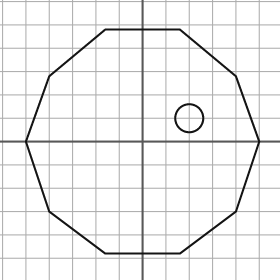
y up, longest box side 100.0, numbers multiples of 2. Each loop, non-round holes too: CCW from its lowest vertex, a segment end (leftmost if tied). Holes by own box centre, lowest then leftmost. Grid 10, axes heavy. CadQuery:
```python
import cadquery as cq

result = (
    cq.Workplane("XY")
    .moveTo(-16.0, -48.0)
    .lineTo(16.0, -48.0)
    .lineTo(40.0, -30.0)
    .lineTo(50.0, 0.0)
    .lineTo(40.0, 28.0)
    .lineTo(16.0, 48.0)
    .lineTo(-16.0, 48.0)
    .lineTo(-40.0, 28.0)
    .lineTo(-50.0, 0.0)
    .lineTo(-40.0, -30.0)
    .close()
    .moveTo(20.0, 10.0)
    .circle(6.0)
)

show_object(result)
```